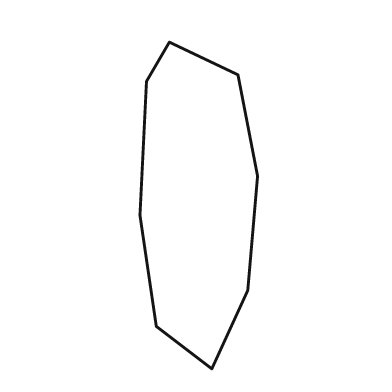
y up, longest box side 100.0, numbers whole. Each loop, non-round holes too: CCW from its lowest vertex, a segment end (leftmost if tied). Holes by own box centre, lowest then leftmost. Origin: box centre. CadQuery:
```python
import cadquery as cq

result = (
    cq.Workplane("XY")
    .moveTo(4.0, -50.0)
    .lineTo(15.0, -26.0)
    .lineTo(18.0, 9.0)
    .lineTo(12.0, 40.0)
    .lineTo(-9.0, 50.0)
    .lineTo(-16.0, 38.0)
    .lineTo(-18.0, -3.0)
    .lineTo(-13.0, -37.0)
    .close()
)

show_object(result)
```